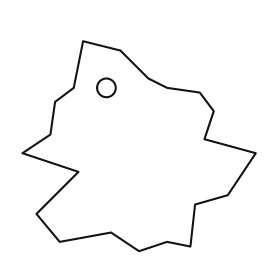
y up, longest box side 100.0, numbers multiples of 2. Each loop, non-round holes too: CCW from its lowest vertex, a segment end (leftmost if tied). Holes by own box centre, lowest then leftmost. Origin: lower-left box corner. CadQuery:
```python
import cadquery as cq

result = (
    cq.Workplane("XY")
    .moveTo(50.0, 0.0)
    .lineTo(62.0, 4.0)
    .lineTo(72.0, 2.0)
    .lineTo(74.0, 20.0)
    .lineTo(88.0, 24.0)
    .lineTo(100.0, 42.0)
    .lineTo(78.0, 48.0)
    .lineTo(82.0, 60.0)
    .lineTo(76.0, 68.0)
    .lineTo(62.0, 70.0)
    .lineTo(54.0, 74.0)
    .lineTo(42.0, 86.0)
    .lineTo(26.0, 90.0)
    .lineTo(22.0, 70.0)
    .lineTo(14.0, 64.0)
    .lineTo(12.0, 50.0)
    .lineTo(0.0, 42.0)
    .lineTo(24.0, 34.0)
    .lineTo(6.0, 16.0)
    .lineTo(16.0, 4.0)
    .lineTo(38.0, 8.0)
    .close()
    .moveTo(36.0, 70.0)
    .circle(4.0)
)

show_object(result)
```